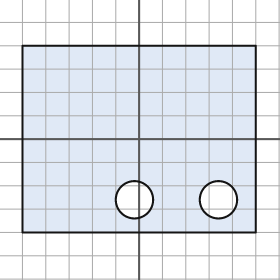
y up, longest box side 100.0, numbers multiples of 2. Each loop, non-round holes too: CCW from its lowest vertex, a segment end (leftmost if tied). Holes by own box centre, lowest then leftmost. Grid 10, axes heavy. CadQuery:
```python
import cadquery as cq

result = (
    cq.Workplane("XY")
    .moveTo(-50.0, -40.0)
    .lineTo(50.0, -40.0)
    .lineTo(50.0, 40.0)
    .lineTo(-50.0, 40.0)
    .close()
    .moveTo(-2.0, -26.0)
    .circle(8.0)
    .moveTo(34.0, -26.0)
    .circle(8.0)
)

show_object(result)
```